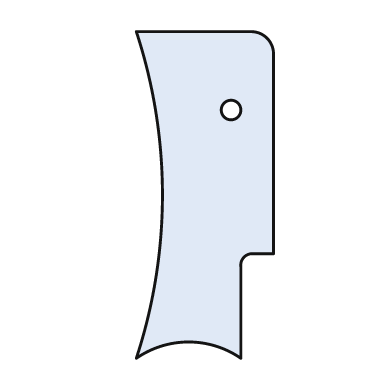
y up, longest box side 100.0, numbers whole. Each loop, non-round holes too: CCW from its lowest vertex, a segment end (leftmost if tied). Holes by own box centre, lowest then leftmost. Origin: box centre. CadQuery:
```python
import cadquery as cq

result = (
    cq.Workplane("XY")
    .moveTo(-21.0, -50.0)
    .threePointArc((-5.0, -45.0), (11.0, -50.0))
    .lineTo(11.0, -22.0)
    .threePointArc((12.0, -19.0), (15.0, -18.0))
    .lineTo(21.0, -18.0)
    .lineTo(21.0, 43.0)
    .threePointArc((19.0, 48.0), (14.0, 50.0))
    .lineTo(-21.0, 50.0)
    .threePointArc((-13.0, 0.0), (-21.0, -50.0))
    .close()
    .moveTo(8.0, 26.0)
    .circle(3.0)
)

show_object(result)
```